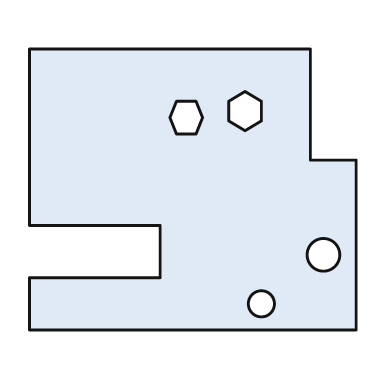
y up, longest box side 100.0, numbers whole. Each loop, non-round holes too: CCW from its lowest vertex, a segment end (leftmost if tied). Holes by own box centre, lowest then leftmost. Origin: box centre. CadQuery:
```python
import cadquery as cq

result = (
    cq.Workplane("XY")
    .moveTo(-50.0, -43.0)
    .lineTo(50.0, -43.0)
    .lineTo(50.0, 9.0)
    .lineTo(36.0, 9.0)
    .lineTo(36.0, 43.0)
    .lineTo(-50.0, 43.0)
    .lineTo(-50.0, -11.0)
    .lineTo(-10.0, -11.0)
    .lineTo(-10.0, -27.0)
    .lineTo(-50.0, -27.0)
    .close()
    .moveTo(21.0, -35.0)
    .circle(4.0)
    .moveTo(40.0, -20.0)
    .circle(5.0)
    .moveTo(-5.0, 17.0)
    .lineTo(1.0, 17.0)
    .lineTo(3.0, 22.0)
    .lineTo(1.0, 27.0)
    .lineTo(-5.0, 27.0)
    .lineTo(-7.0, 22.0)
    .close()
    .moveTo(16.0, 18.0)
    .lineTo(21.0, 21.0)
    .lineTo(21.0, 27.0)
    .lineTo(16.0, 30.0)
    .lineTo(11.0, 27.0)
    .lineTo(11.0, 21.0)
    .close()
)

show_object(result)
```